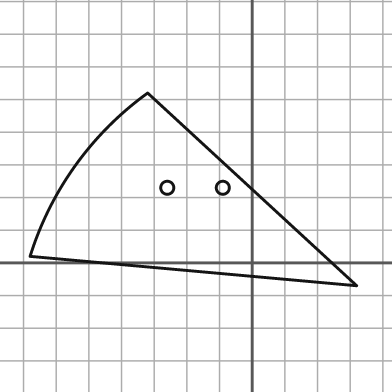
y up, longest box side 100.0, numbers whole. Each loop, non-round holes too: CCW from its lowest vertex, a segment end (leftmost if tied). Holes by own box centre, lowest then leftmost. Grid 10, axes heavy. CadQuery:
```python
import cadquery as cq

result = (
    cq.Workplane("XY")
    .moveTo(32.0, -7.0)
    .lineTo(-32.0, 52.0)
    .threePointArc((-54.0, 30.0), (-68.0, 2.0))
    .close()
    .moveTo(-26.0, 23.0)
    .circle(2.0)
    .moveTo(-9.0, 23.0)
    .circle(2.0)
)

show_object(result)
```